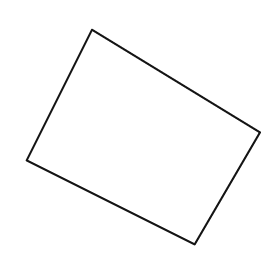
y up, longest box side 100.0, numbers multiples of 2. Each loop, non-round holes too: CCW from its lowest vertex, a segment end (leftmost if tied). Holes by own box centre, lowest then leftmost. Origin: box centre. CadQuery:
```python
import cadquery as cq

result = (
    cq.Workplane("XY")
    .moveTo(22.0, -46.0)
    .lineTo(50.0, 2.0)
    .lineTo(-22.0, 46.0)
    .lineTo(-50.0, -10.0)
    .close()
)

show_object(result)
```